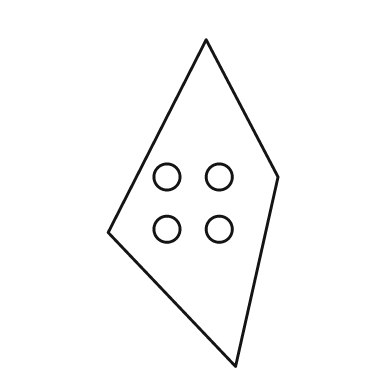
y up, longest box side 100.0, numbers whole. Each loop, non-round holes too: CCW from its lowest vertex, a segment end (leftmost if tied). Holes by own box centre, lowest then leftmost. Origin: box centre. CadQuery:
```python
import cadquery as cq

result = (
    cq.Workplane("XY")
    .moveTo(13.0, -50.0)
    .lineTo(26.0, 8.0)
    .lineTo(4.0, 50.0)
    .lineTo(-26.0, -9.0)
    .close()
    .moveTo(-8.0, -8.0)
    .circle(4.0)
    .moveTo(8.0, -8.0)
    .circle(4.0)
    .moveTo(-8.0, 8.0)
    .circle(4.0)
    .moveTo(8.0, 8.0)
    .circle(4.0)
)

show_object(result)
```